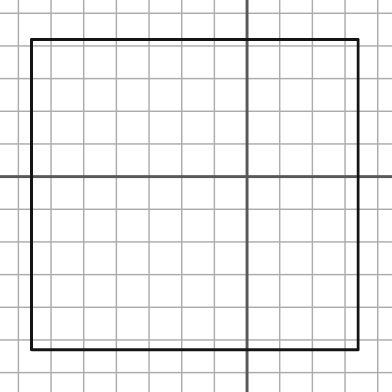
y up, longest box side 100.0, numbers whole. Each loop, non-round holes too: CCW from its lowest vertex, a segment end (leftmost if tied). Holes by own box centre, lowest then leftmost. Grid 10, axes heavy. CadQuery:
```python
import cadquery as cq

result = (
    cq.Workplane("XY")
    .moveTo(-66.0, -53.0)
    .lineTo(34.0, -53.0)
    .lineTo(34.0, 42.0)
    .lineTo(-66.0, 42.0)
    .close()
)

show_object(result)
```